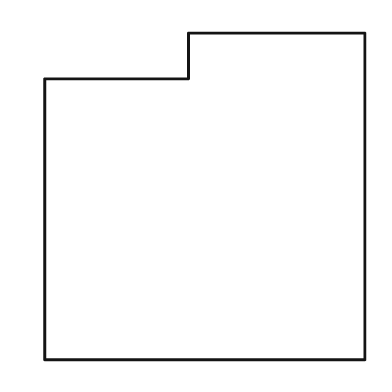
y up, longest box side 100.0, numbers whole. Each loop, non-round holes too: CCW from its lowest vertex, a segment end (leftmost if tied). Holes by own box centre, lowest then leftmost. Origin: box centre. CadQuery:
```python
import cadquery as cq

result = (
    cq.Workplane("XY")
    .moveTo(-49.0, -50.0)
    .lineTo(49.0, -50.0)
    .lineTo(49.0, 50.0)
    .lineTo(-5.0, 50.0)
    .lineTo(-5.0, 36.0)
    .lineTo(-49.0, 36.0)
    .close()
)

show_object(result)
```